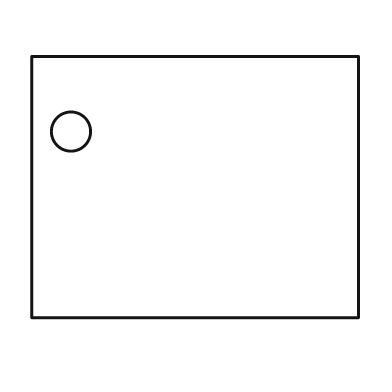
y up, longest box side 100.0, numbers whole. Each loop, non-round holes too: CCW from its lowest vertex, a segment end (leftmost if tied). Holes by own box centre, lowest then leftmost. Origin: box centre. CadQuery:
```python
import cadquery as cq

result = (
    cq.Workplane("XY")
    .moveTo(-50.0, -40.0)
    .lineTo(50.0, -40.0)
    .lineTo(50.0, 40.0)
    .lineTo(-50.0, 40.0)
    .close()
    .moveTo(-38.0, 17.0)
    .circle(6.0)
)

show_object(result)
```